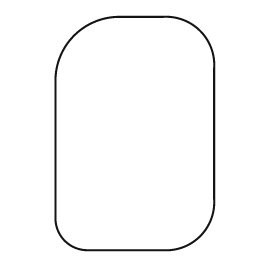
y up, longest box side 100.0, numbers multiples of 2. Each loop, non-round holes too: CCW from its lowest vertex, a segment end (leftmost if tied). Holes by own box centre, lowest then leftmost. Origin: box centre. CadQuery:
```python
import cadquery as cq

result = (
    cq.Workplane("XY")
    .moveTo(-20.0, -50.0)
    .lineTo(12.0, -50.0)
    .threePointArc((28.0, -44.0), (34.0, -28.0))
    .lineTo(34.0, 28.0)
    .threePointArc((28.0, 44.0), (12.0, 50.0))
    .lineTo(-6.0, 50.0)
    .threePointArc((-26.0, 42.0), (-34.0, 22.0))
    .lineTo(-34.0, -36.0)
    .threePointArc((-30.0, -46.0), (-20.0, -50.0))
    .close()
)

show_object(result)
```